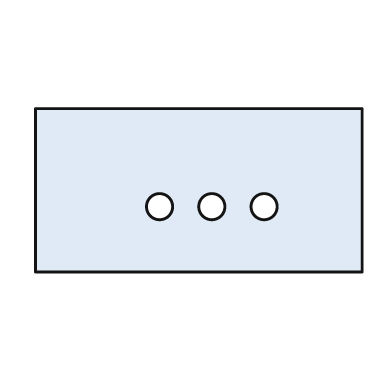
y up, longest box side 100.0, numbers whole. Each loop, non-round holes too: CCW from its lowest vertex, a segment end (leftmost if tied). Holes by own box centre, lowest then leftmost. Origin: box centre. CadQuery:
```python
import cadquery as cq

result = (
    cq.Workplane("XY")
    .moveTo(-50.0, -25.0)
    .lineTo(50.0, -25.0)
    .lineTo(50.0, 25.0)
    .lineTo(-50.0, 25.0)
    .close()
    .moveTo(-12.0, -5.0)
    .circle(4.0)
    .moveTo(4.0, -5.0)
    .circle(4.0)
    .moveTo(20.0, -5.0)
    .circle(4.0)
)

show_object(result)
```